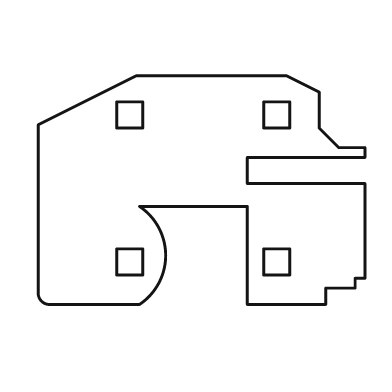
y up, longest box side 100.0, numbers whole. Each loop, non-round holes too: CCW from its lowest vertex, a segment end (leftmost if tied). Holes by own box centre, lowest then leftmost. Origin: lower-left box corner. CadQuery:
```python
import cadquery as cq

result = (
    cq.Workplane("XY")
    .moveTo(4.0, 0.0)
    .lineTo(31.0, 0.0)
    .threePointArc((39.0, 15.0), (31.0, 30.0))
    .lineTo(64.0, 30.0)
    .lineTo(64.0, 0.0)
    .lineTo(88.0, 0.0)
    .lineTo(88.0, 5.0)
    .lineTo(97.0, 5.0)
    .lineTo(97.0, 8.0)
    .lineTo(100.0, 8.0)
    .lineTo(100.0, 37.0)
    .lineTo(64.0, 37.0)
    .lineTo(64.0, 45.0)
    .lineTo(100.0, 45.0)
    .lineTo(100.0, 48.0)
    .lineTo(92.0, 48.0)
    .lineTo(86.0, 54.0)
    .lineTo(86.0, 65.0)
    .lineTo(76.0, 70.0)
    .lineTo(30.0, 70.0)
    .lineTo(0.0, 55.0)
    .lineTo(0.0, 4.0)
    .threePointArc((1.0, 1.0), (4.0, 0.0))
    .close()
    .moveTo(24.0, 9.0)
    .lineTo(32.0, 9.0)
    .lineTo(32.0, 17.0)
    .lineTo(24.0, 17.0)
    .close()
    .moveTo(69.0, 9.0)
    .lineTo(77.0, 9.0)
    .lineTo(77.0, 17.0)
    .lineTo(69.0, 17.0)
    .close()
    .moveTo(24.0, 54.0)
    .lineTo(32.0, 54.0)
    .lineTo(32.0, 62.0)
    .lineTo(24.0, 62.0)
    .close()
    .moveTo(69.0, 54.0)
    .lineTo(77.0, 54.0)
    .lineTo(77.0, 62.0)
    .lineTo(69.0, 62.0)
    .close()
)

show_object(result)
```